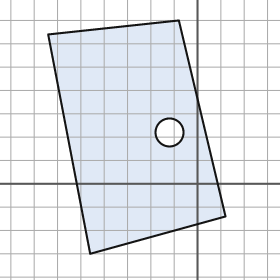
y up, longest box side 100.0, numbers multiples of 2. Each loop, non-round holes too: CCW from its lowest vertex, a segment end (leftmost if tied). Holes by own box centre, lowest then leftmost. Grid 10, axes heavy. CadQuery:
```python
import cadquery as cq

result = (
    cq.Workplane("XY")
    .moveTo(-46.0, -30.0)
    .lineTo(12.0, -14.0)
    .lineTo(-8.0, 70.0)
    .lineTo(-64.0, 64.0)
    .close()
    .moveTo(-12.0, 22.0)
    .circle(6.0)
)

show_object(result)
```